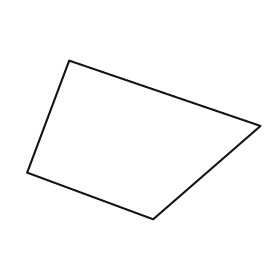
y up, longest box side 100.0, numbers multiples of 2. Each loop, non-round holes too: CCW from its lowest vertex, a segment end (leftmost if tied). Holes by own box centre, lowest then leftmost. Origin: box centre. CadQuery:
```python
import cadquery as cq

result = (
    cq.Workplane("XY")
    .moveTo(4.0, -34.0)
    .lineTo(50.0, 6.0)
    .lineTo(-32.0, 34.0)
    .lineTo(-50.0, -14.0)
    .close()
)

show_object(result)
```